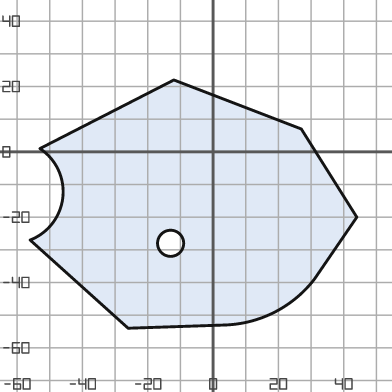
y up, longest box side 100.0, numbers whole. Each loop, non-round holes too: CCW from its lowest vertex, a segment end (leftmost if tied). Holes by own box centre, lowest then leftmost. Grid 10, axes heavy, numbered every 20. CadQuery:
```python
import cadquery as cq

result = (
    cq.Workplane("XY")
    .moveTo(-26.0, -54.0)
    .lineTo(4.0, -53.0)
    .threePointArc((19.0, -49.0), (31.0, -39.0))
    .lineTo(44.0, -20.0)
    .lineTo(27.0, 7.0)
    .lineTo(-12.0, 22.0)
    .lineTo(-53.0, 1.0)
    .threePointArc((-46.0, -14.0), (-56.0, -27.0))
    .close()
    .moveTo(-13.0, -28.0)
    .circle(4.0)
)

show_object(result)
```